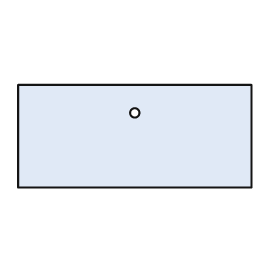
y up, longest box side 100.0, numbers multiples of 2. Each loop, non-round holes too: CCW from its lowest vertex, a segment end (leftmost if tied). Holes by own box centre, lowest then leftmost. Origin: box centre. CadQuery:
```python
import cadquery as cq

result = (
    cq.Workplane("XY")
    .moveTo(-50.0, -22.0)
    .lineTo(50.0, -22.0)
    .lineTo(50.0, 22.0)
    .lineTo(-50.0, 22.0)
    .close()
    .moveTo(0.0, 10.0)
    .circle(2.0)
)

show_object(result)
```